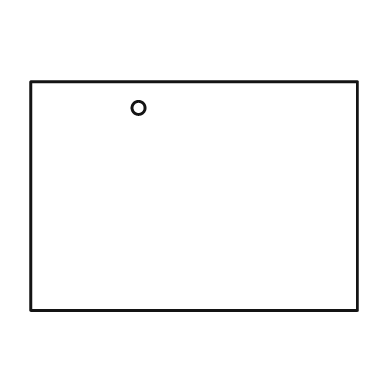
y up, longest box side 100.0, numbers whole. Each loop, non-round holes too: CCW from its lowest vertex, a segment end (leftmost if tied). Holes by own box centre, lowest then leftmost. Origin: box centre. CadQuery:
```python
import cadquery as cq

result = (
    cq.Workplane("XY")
    .moveTo(-50.0, -35.0)
    .lineTo(50.0, -35.0)
    .lineTo(50.0, 35.0)
    .lineTo(-50.0, 35.0)
    .close()
    .moveTo(-17.0, 27.0)
    .circle(2.0)
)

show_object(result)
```